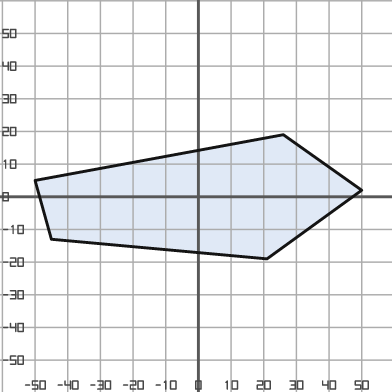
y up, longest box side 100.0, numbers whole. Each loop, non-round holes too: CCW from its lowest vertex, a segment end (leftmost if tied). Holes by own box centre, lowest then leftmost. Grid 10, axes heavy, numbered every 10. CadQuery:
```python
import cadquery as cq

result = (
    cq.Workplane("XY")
    .moveTo(21.0, -19.0)
    .lineTo(50.0, 2.0)
    .lineTo(26.0, 19.0)
    .lineTo(-50.0, 5.0)
    .lineTo(-45.0, -13.0)
    .close()
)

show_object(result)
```